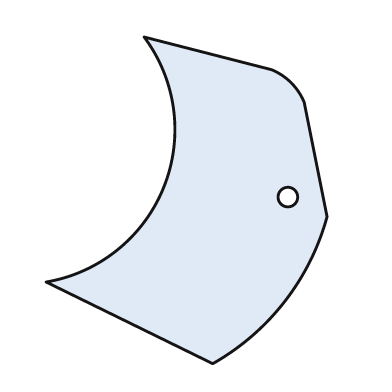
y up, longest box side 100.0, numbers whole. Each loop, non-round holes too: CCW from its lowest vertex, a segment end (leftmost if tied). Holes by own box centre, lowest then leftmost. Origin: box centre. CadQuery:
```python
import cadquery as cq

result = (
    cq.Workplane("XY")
    .moveTo(8.0, -50.0)
    .threePointArc((30.0, -31.0), (43.0, -5.0))
    .lineTo(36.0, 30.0)
    .threePointArc((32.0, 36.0), (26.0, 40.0))
    .lineTo(-13.0, 50.0)
    .threePointArc((-7.0, 4.0), (-43.0, -25.0))
    .close()
    .moveTo(31.0, 1.0)
    .circle(3.0)
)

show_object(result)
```